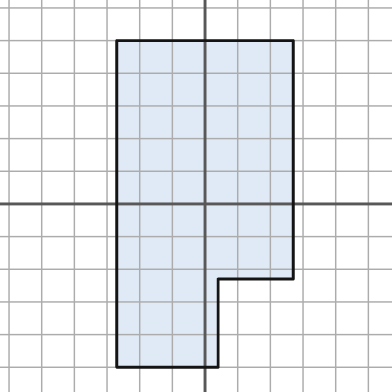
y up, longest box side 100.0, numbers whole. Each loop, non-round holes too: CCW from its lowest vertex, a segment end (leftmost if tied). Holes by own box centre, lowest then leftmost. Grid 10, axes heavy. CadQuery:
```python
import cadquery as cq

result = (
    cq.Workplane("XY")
    .moveTo(-27.0, -50.0)
    .lineTo(4.0, -50.0)
    .lineTo(4.0, -23.0)
    .lineTo(27.0, -23.0)
    .lineTo(27.0, 50.0)
    .lineTo(-27.0, 50.0)
    .close()
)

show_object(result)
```